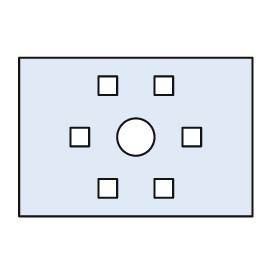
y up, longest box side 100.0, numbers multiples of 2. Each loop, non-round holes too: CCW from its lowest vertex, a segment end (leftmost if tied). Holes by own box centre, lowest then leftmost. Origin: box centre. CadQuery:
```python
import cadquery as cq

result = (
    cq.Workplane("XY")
    .moveTo(-50.0, -34.0)
    .lineTo(50.0, -34.0)
    .lineTo(50.0, 34.0)
    .lineTo(-50.0, 34.0)
    .close()
    .moveTo(-16.0, -26.0)
    .lineTo(-8.0, -26.0)
    .lineTo(-8.0, -18.0)
    .lineTo(-16.0, -18.0)
    .close()
    .moveTo(8.0, -26.0)
    .lineTo(16.0, -26.0)
    .lineTo(16.0, -18.0)
    .lineTo(8.0, -18.0)
    .close()
    .moveTo(-28.0, -4.0)
    .lineTo(-20.0, -4.0)
    .lineTo(-20.0, 4.0)
    .lineTo(-28.0, 4.0)
    .close()
    .moveTo(0.0, 0.0)
    .circle(8.0)
    .moveTo(20.0, -4.0)
    .lineTo(28.0, -4.0)
    .lineTo(28.0, 4.0)
    .lineTo(20.0, 4.0)
    .close()
    .moveTo(-16.0, 18.0)
    .lineTo(-8.0, 18.0)
    .lineTo(-8.0, 26.0)
    .lineTo(-16.0, 26.0)
    .close()
    .moveTo(8.0, 18.0)
    .lineTo(16.0, 18.0)
    .lineTo(16.0, 26.0)
    .lineTo(8.0, 26.0)
    .close()
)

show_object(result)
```